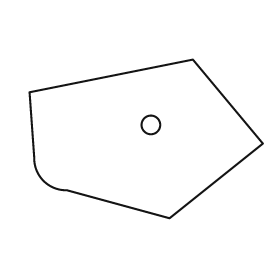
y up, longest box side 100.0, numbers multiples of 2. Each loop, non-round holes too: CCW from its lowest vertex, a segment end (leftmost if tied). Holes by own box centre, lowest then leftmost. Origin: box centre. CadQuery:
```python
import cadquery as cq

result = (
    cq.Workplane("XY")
    .moveTo(10.0, -34.0)
    .lineTo(50.0, -2.0)
    .lineTo(20.0, 34.0)
    .lineTo(-50.0, 20.0)
    .lineTo(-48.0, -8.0)
    .threePointArc((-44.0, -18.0), (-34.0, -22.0))
    .close()
    .moveTo(2.0, 6.0)
    .circle(4.0)
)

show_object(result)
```